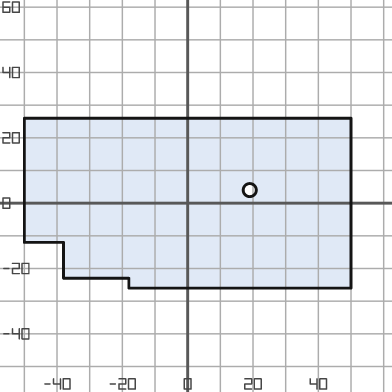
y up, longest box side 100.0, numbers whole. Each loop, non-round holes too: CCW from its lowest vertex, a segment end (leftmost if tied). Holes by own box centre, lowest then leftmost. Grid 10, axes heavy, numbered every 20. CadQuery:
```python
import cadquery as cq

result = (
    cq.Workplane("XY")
    .moveTo(-18.0, -26.0)
    .lineTo(50.0, -26.0)
    .lineTo(50.0, 26.0)
    .lineTo(-50.0, 26.0)
    .lineTo(-50.0, -12.0)
    .lineTo(-38.0, -12.0)
    .lineTo(-38.0, -23.0)
    .lineTo(-18.0, -23.0)
    .close()
    .moveTo(19.0, 4.0)
    .circle(2.0)
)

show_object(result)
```